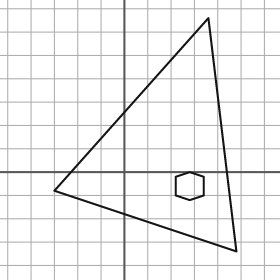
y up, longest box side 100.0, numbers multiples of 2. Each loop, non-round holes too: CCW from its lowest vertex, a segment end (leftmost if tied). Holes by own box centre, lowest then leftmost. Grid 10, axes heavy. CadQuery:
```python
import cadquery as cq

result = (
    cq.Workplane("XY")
    .moveTo(48.0, -34.0)
    .lineTo(36.0, 66.0)
    .lineTo(-30.0, -8.0)
    .close()
    .moveTo(28.0, -12.0)
    .lineTo(34.0, -10.0)
    .lineTo(34.0, -2.0)
    .lineTo(28.0, 0.0)
    .lineTo(22.0, -2.0)
    .lineTo(22.0, -10.0)
    .close()
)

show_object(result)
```